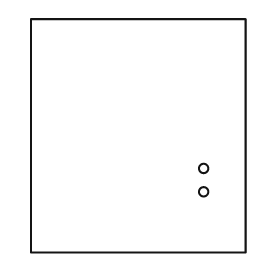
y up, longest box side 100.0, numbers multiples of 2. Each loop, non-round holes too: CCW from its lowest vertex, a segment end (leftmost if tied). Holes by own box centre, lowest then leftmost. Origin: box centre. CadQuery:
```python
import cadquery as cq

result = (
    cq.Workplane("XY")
    .moveTo(-46.0, -50.0)
    .lineTo(46.0, -50.0)
    .lineTo(46.0, 50.0)
    .lineTo(-46.0, 50.0)
    .close()
    .moveTo(28.0, -24.0)
    .circle(2.0)
    .moveTo(28.0, -14.0)
    .circle(2.0)
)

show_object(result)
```